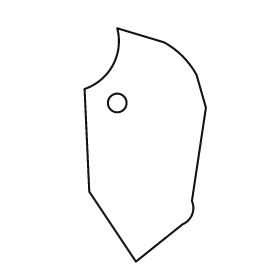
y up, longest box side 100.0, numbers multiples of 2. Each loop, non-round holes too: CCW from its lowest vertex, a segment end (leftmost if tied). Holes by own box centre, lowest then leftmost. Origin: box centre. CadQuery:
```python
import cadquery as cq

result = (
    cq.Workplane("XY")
    .moveTo(-4.0, -50.0)
    .lineTo(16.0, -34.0)
    .threePointArc((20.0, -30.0), (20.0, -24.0))
    .lineTo(26.0, 16.0)
    .lineTo(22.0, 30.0)
    .threePointArc((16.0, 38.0), (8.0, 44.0))
    .lineTo(-12.0, 50.0)
    .threePointArc((-14.0, 34.0), (-26.0, 24.0))
    .lineTo(-24.0, -20.0)
    .close()
    .moveTo(-12.0, 18.0)
    .circle(4.0)
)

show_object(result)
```